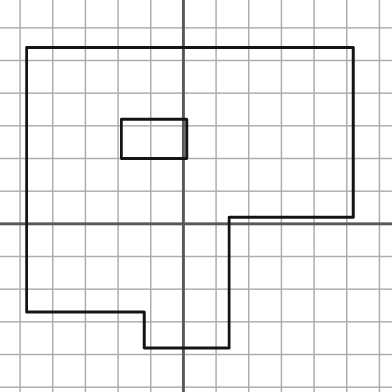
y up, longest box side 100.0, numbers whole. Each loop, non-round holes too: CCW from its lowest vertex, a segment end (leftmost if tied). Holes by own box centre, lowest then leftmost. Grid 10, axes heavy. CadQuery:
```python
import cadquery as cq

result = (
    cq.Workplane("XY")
    .moveTo(-12.0, -38.0)
    .lineTo(14.0, -38.0)
    .lineTo(14.0, 2.0)
    .lineTo(52.0, 2.0)
    .lineTo(52.0, 54.0)
    .lineTo(-48.0, 54.0)
    .lineTo(-48.0, -27.0)
    .lineTo(-12.0, -27.0)
    .close()
    .moveTo(-19.0, 20.0)
    .lineTo(1.0, 20.0)
    .lineTo(1.0, 32.0)
    .lineTo(-19.0, 32.0)
    .close()
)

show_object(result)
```